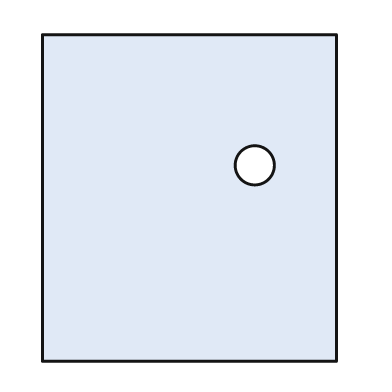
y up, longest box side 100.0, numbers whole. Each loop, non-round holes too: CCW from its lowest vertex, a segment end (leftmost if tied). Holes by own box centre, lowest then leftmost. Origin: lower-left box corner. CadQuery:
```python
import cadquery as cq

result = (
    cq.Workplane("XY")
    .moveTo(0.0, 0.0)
    .lineTo(90.0, 0.0)
    .lineTo(90.0, 100.0)
    .lineTo(0.0, 100.0)
    .close()
    .moveTo(65.0, 60.0)
    .circle(6.0)
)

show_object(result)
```